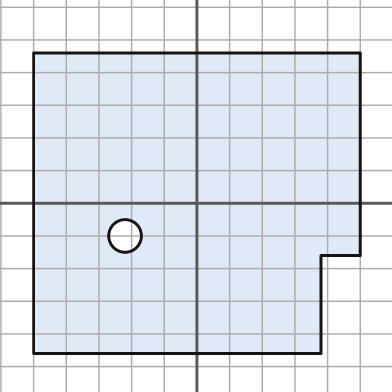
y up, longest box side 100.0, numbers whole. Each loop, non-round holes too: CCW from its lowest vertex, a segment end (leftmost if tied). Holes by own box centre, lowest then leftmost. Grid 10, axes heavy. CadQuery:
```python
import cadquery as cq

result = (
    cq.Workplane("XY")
    .moveTo(-50.0, -46.0)
    .lineTo(38.0, -46.0)
    .lineTo(38.0, -16.0)
    .lineTo(50.0, -16.0)
    .lineTo(50.0, 46.0)
    .lineTo(-50.0, 46.0)
    .close()
    .moveTo(-22.0, -10.0)
    .circle(5.0)
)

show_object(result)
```